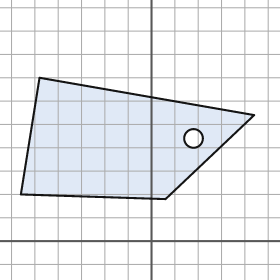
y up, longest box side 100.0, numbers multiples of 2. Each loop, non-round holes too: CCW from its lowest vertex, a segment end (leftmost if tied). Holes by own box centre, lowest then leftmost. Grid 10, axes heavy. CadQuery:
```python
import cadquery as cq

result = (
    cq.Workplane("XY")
    .moveTo(6.0, 18.0)
    .lineTo(44.0, 54.0)
    .lineTo(-48.0, 70.0)
    .lineTo(-56.0, 20.0)
    .close()
    .moveTo(18.0, 44.0)
    .circle(4.0)
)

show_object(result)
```